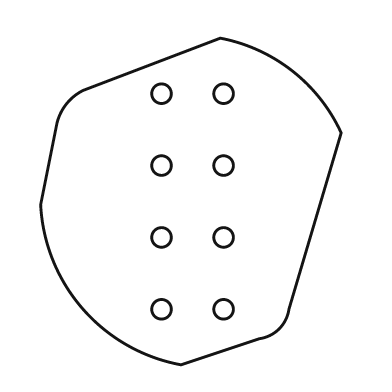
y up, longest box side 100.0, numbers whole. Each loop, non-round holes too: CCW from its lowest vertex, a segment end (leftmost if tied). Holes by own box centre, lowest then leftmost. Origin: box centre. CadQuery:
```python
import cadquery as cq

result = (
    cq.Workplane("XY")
    .moveTo(-3.0, -50.0)
    .lineTo(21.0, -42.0)
    .threePointArc((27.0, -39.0), (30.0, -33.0))
    .lineTo(46.0, 21.0)
    .threePointArc((31.0, 40.0), (9.0, 50.0))
    .lineTo(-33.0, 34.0)
    .threePointArc((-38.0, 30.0), (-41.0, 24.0))
    .lineTo(-46.0, -1.0)
    .threePointArc((-33.0, -33.0), (-3.0, -50.0))
    .close()
    .moveTo(-9.0, -33.0)
    .circle(3.0)
    .moveTo(10.0, -33.0)
    .circle(3.0)
    .moveTo(-9.0, -11.0)
    .circle(3.0)
    .moveTo(10.0, -11.0)
    .circle(3.0)
    .moveTo(-9.0, 11.0)
    .circle(3.0)
    .moveTo(10.0, 11.0)
    .circle(3.0)
    .moveTo(-9.0, 33.0)
    .circle(3.0)
    .moveTo(10.0, 33.0)
    .circle(3.0)
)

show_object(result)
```